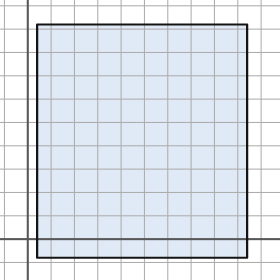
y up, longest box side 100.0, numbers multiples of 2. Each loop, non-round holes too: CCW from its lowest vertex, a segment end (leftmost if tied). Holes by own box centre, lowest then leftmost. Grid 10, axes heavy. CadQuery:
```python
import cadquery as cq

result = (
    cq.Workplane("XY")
    .moveTo(4.0, -8.0)
    .lineTo(94.0, -8.0)
    .lineTo(94.0, 92.0)
    .lineTo(4.0, 92.0)
    .close()
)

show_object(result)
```